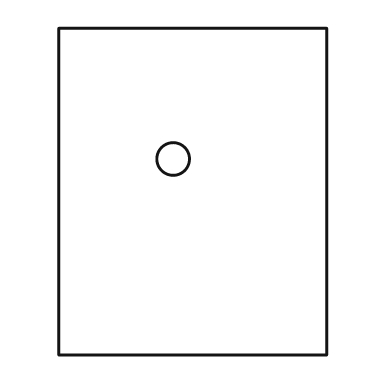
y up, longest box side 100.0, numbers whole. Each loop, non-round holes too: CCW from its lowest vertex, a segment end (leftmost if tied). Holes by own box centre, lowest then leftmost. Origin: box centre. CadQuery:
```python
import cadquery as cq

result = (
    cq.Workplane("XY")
    .moveTo(-41.0, -50.0)
    .lineTo(41.0, -50.0)
    .lineTo(41.0, 50.0)
    .lineTo(-41.0, 50.0)
    .close()
    .moveTo(-6.0, 10.0)
    .circle(5.0)
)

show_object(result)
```